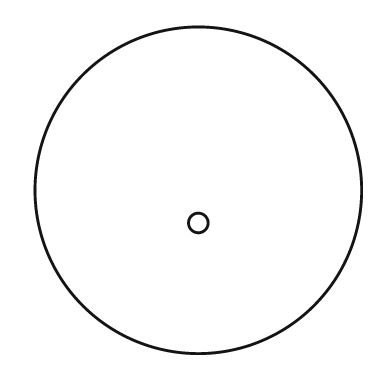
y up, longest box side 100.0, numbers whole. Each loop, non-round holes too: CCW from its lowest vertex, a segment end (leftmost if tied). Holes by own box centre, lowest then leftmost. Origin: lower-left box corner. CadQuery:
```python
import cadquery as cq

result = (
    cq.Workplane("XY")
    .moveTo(50.0, 50.0)
    .circle(50.0)
    .moveTo(50.0, 40.0)
    .circle(3.0)
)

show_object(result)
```